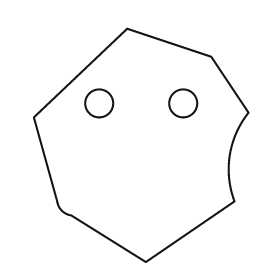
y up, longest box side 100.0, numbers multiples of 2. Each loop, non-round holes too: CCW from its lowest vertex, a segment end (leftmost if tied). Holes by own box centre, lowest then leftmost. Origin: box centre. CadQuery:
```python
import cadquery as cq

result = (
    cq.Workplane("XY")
    .moveTo(2.0, -50.0)
    .lineTo(40.0, -24.0)
    .threePointArc((38.0, -4.0), (46.0, 14.0))
    .lineTo(30.0, 38.0)
    .lineTo(-6.0, 50.0)
    .lineTo(-46.0, 12.0)
    .lineTo(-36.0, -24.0)
    .threePointArc((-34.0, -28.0), (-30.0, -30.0))
    .close()
    .moveTo(-18.0, 18.0)
    .circle(6.0)
    .moveTo(18.0, 18.0)
    .circle(6.0)
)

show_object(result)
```